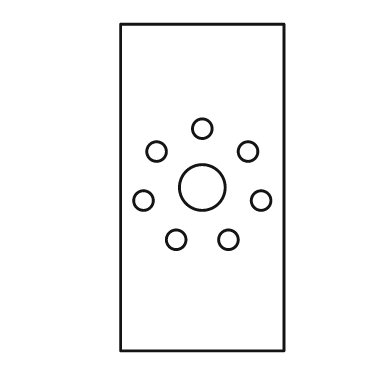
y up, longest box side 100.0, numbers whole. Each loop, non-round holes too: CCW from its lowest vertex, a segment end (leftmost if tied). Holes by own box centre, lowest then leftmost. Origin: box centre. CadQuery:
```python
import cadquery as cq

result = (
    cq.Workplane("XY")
    .moveTo(-25.0, -50.0)
    .lineTo(25.0, -50.0)
    .lineTo(25.0, 50.0)
    .lineTo(-25.0, 50.0)
    .close()
    .moveTo(-8.0, -16.0)
    .circle(3.0)
    .moveTo(8.0, -16.0)
    .circle(3.0)
    .moveTo(-18.0, -4.0)
    .circle(3.0)
    .moveTo(18.0, -4.0)
    .circle(3.0)
    .moveTo(0.0, 0.0)
    .circle(7.0)
    .moveTo(-14.0, 11.0)
    .circle(3.0)
    .moveTo(14.0, 11.0)
    .circle(3.0)
    .moveTo(0.0, 18.0)
    .circle(3.0)
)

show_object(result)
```